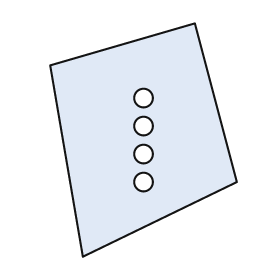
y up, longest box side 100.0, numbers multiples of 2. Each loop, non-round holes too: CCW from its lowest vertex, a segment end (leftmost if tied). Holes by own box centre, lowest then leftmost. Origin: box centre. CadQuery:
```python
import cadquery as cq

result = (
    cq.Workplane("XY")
    .moveTo(-26.0, -50.0)
    .lineTo(40.0, -18.0)
    .lineTo(22.0, 50.0)
    .lineTo(-40.0, 32.0)
    .close()
    .moveTo(0.0, -18.0)
    .circle(4.0)
    .moveTo(0.0, -6.0)
    .circle(4.0)
    .moveTo(0.0, 6.0)
    .circle(4.0)
    .moveTo(0.0, 18.0)
    .circle(4.0)
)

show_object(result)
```